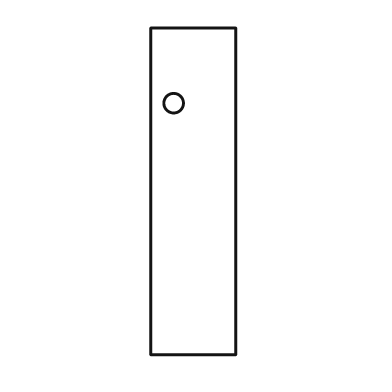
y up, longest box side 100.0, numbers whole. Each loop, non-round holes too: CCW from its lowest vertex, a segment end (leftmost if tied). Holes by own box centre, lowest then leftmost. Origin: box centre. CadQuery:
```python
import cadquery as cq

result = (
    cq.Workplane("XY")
    .moveTo(-13.0, -50.0)
    .lineTo(13.0, -50.0)
    .lineTo(13.0, 50.0)
    .lineTo(-13.0, 50.0)
    .close()
    .moveTo(-6.0, 27.0)
    .circle(3.0)
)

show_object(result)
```